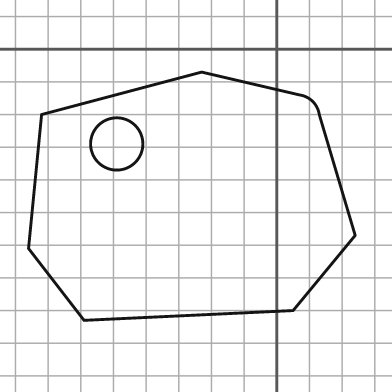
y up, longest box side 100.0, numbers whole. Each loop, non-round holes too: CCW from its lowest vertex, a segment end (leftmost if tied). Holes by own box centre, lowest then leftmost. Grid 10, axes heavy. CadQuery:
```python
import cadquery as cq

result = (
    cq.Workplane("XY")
    .moveTo(-59.0, -83.0)
    .lineTo(5.0, -80.0)
    .lineTo(24.0, -57.0)
    .lineTo(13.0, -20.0)
    .threePointArc((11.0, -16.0), (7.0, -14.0))
    .lineTo(-23.0, -7.0)
    .lineTo(-72.0, -20.0)
    .lineTo(-76.0, -61.0)
    .close()
    .moveTo(-49.0, -29.0)
    .circle(8.0)
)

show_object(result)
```